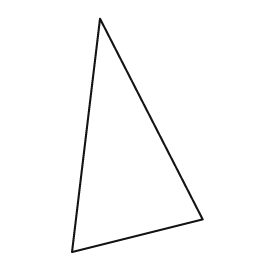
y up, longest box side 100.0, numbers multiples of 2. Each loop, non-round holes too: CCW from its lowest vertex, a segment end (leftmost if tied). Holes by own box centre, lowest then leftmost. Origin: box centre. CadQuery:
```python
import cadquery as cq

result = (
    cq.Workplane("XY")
    .moveTo(-28.0, -50.0)
    .lineTo(28.0, -36.0)
    .lineTo(-16.0, 50.0)
    .close()
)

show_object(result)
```